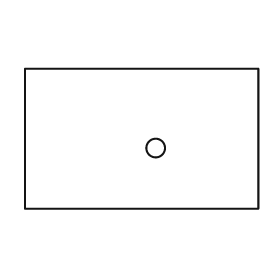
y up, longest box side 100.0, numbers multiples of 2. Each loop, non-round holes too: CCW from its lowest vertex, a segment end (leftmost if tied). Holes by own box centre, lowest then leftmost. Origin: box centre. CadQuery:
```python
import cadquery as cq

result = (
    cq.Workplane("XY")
    .moveTo(-50.0, -30.0)
    .lineTo(50.0, -30.0)
    .lineTo(50.0, 30.0)
    .lineTo(-50.0, 30.0)
    .close()
    .moveTo(6.0, -4.0)
    .circle(4.0)
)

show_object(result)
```